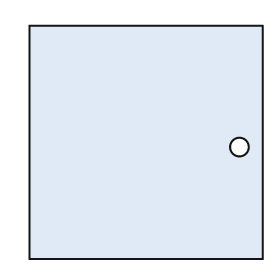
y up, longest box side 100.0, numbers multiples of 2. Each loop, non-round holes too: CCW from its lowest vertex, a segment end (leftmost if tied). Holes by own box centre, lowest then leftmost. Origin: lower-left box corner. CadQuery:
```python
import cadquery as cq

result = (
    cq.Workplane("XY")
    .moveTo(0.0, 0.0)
    .lineTo(100.0, 0.0)
    .lineTo(100.0, 100.0)
    .lineTo(0.0, 100.0)
    .close()
    .moveTo(90.0, 48.0)
    .circle(4.0)
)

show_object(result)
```